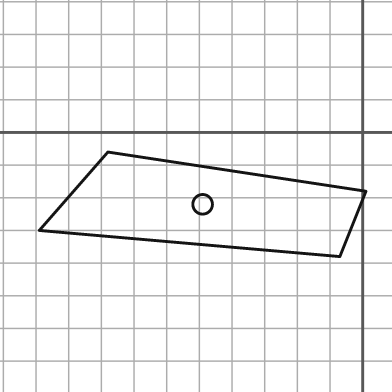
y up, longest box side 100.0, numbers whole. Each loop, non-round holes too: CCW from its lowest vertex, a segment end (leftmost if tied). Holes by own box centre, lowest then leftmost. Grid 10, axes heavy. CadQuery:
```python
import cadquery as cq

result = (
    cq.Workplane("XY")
    .moveTo(-7.0, -38.0)
    .lineTo(1.0, -18.0)
    .lineTo(-78.0, -6.0)
    .lineTo(-99.0, -30.0)
    .close()
    .moveTo(-49.0, -22.0)
    .circle(3.0)
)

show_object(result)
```